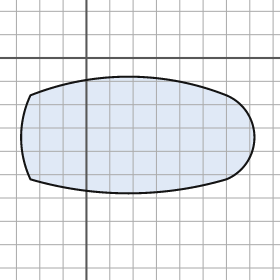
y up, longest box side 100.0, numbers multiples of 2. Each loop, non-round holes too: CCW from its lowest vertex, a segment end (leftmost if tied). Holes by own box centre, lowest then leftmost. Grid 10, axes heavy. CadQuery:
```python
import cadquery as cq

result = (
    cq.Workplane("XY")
    .moveTo(-24.0, -52.0)
    .threePointArc((18.0, -58.0), (60.0, -52.0))
    .threePointArc((72.0, -34.0), (60.0, -16.0))
    .threePointArc((18.0, -8.0), (-24.0, -16.0))
    .threePointArc((-28.0, -34.0), (-24.0, -52.0))
    .close()
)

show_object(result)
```